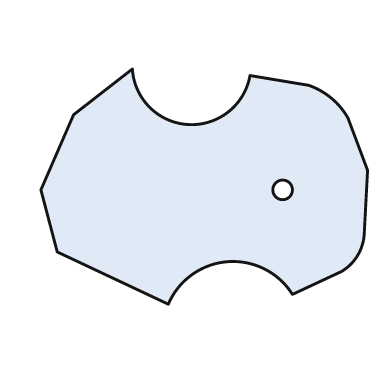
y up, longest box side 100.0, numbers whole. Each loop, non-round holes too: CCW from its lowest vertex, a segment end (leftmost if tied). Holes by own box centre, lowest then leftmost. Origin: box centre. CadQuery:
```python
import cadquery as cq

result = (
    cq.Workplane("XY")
    .moveTo(-11.0, -36.0)
    .threePointArc((7.0, -23.0), (27.0, -33.0))
    .lineTo(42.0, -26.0)
    .threePointArc((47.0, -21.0), (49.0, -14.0))
    .lineTo(50.0, 5.0)
    .lineTo(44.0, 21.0)
    .threePointArc((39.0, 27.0), (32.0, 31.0))
    .lineTo(14.0, 34.0)
    .threePointArc((-5.0, 19.0), (-22.0, 36.0))
    .lineTo(-40.0, 22.0)
    .lineTo(-50.0, -1.0)
    .lineTo(-45.0, -20.0)
    .close()
    .moveTo(24.0, -1.0)
    .circle(3.0)
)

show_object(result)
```